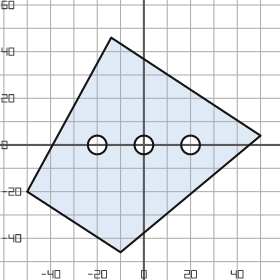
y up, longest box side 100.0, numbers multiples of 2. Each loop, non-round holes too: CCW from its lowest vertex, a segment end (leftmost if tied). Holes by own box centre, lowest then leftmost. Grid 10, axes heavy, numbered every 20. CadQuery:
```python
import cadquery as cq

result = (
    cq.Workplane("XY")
    .moveTo(-10.0, -46.0)
    .lineTo(50.0, 4.0)
    .lineTo(-14.0, 46.0)
    .lineTo(-50.0, -20.0)
    .close()
    .moveTo(-20.0, 0.0)
    .circle(4.0)
    .moveTo(0.0, 0.0)
    .circle(4.0)
    .moveTo(20.0, 0.0)
    .circle(4.0)
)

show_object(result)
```